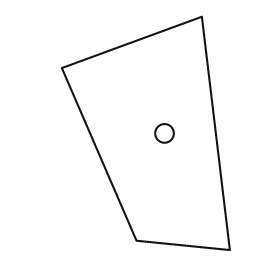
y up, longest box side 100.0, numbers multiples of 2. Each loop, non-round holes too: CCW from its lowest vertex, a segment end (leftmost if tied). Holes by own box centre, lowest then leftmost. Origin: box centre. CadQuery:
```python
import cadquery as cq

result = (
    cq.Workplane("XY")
    .moveTo(36.0, -50.0)
    .lineTo(24.0, 50.0)
    .lineTo(-36.0, 28.0)
    .lineTo(-4.0, -46.0)
    .close()
    .moveTo(8.0, 0.0)
    .circle(4.0)
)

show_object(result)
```